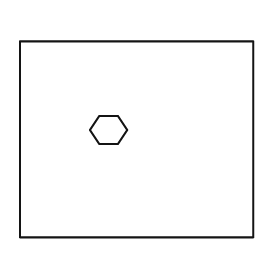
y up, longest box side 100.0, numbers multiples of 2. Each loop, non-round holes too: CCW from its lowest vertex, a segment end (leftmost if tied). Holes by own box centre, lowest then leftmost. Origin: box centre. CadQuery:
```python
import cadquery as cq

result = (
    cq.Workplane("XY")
    .moveTo(-50.0, -42.0)
    .lineTo(50.0, -42.0)
    .lineTo(50.0, 42.0)
    .lineTo(-50.0, 42.0)
    .close()
    .moveTo(-16.0, -2.0)
    .lineTo(-8.0, -2.0)
    .lineTo(-4.0, 4.0)
    .lineTo(-8.0, 10.0)
    .lineTo(-16.0, 10.0)
    .lineTo(-20.0, 4.0)
    .close()
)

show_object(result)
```